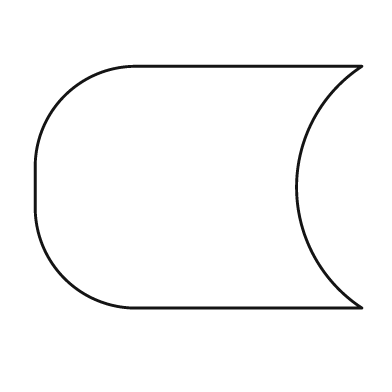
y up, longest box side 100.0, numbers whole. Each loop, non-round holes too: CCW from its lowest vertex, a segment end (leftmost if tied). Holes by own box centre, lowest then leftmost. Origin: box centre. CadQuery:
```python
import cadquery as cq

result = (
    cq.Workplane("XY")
    .moveTo(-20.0, -37.0)
    .lineTo(50.0, -37.0)
    .threePointArc((30.0, 0.0), (50.0, 37.0))
    .lineTo(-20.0, 37.0)
    .threePointArc((-41.0, 28.0), (-50.0, 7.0))
    .lineTo(-50.0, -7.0)
    .threePointArc((-41.0, -28.0), (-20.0, -37.0))
    .close()
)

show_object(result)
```